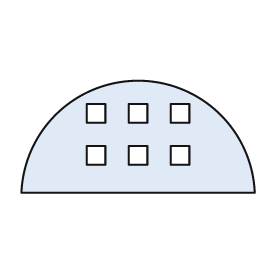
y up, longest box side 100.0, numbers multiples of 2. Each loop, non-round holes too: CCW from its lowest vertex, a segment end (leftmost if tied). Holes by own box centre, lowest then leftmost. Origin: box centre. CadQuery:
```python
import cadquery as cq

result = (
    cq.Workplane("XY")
    .moveTo(-50.0, -24.0)
    .lineTo(50.0, -24.0)
    .threePointArc((0.0, 24.0), (-50.0, -24.0))
    .close()
    .moveTo(-22.0, -12.0)
    .lineTo(-14.0, -12.0)
    .lineTo(-14.0, -4.0)
    .lineTo(-22.0, -4.0)
    .close()
    .moveTo(-4.0, -12.0)
    .lineTo(4.0, -12.0)
    .lineTo(4.0, -4.0)
    .lineTo(-4.0, -4.0)
    .close()
    .moveTo(14.0, -12.0)
    .lineTo(22.0, -12.0)
    .lineTo(22.0, -4.0)
    .lineTo(14.0, -4.0)
    .close()
    .moveTo(-22.0, 6.0)
    .lineTo(-14.0, 6.0)
    .lineTo(-14.0, 14.0)
    .lineTo(-22.0, 14.0)
    .close()
    .moveTo(-4.0, 6.0)
    .lineTo(4.0, 6.0)
    .lineTo(4.0, 14.0)
    .lineTo(-4.0, 14.0)
    .close()
    .moveTo(14.0, 6.0)
    .lineTo(22.0, 6.0)
    .lineTo(22.0, 14.0)
    .lineTo(14.0, 14.0)
    .close()
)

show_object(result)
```